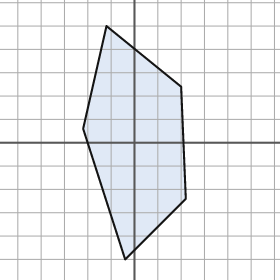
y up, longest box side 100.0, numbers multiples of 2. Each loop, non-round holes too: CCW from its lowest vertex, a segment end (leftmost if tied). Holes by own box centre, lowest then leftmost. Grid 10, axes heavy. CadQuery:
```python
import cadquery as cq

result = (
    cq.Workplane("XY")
    .moveTo(-4.0, -50.0)
    .lineTo(22.0, -24.0)
    .lineTo(20.0, 24.0)
    .lineTo(-12.0, 50.0)
    .lineTo(-22.0, 6.0)
    .close()
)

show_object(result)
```